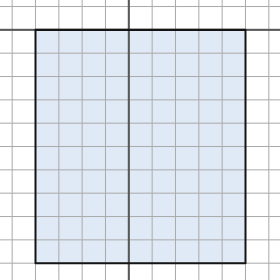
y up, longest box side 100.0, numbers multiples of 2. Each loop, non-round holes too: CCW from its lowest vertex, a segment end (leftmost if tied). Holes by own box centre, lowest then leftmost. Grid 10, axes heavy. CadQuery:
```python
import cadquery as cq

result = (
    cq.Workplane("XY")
    .moveTo(-40.0, -100.0)
    .lineTo(50.0, -100.0)
    .lineTo(50.0, 0.0)
    .lineTo(-40.0, 0.0)
    .close()
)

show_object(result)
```